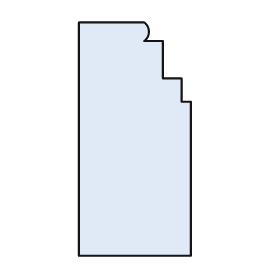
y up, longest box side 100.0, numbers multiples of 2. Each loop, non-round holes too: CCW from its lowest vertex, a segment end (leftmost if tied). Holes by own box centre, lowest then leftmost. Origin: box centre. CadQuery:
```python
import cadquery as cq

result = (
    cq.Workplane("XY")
    .moveTo(-24.0, -50.0)
    .lineTo(24.0, -50.0)
    .lineTo(24.0, 16.0)
    .lineTo(20.0, 16.0)
    .lineTo(20.0, 26.0)
    .lineTo(12.0, 26.0)
    .lineTo(12.0, 42.0)
    .lineTo(4.0, 42.0)
    .threePointArc((6.0, 46.0), (4.0, 50.0))
    .lineTo(-24.0, 50.0)
    .close()
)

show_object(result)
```